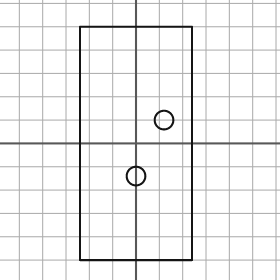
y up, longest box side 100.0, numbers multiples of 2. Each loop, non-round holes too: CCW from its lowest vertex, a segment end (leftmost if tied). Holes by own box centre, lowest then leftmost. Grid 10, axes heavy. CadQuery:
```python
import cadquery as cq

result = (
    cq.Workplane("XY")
    .moveTo(-24.0, -50.0)
    .lineTo(24.0, -50.0)
    .lineTo(24.0, 50.0)
    .lineTo(-24.0, 50.0)
    .close()
    .moveTo(0.0, -14.0)
    .circle(4.0)
    .moveTo(12.0, 10.0)
    .circle(4.0)
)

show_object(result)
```